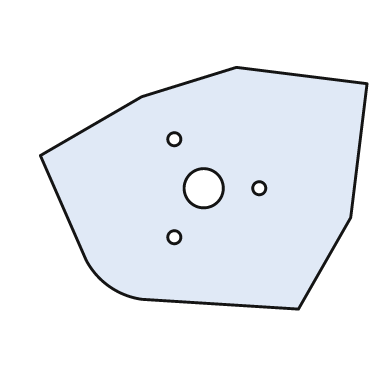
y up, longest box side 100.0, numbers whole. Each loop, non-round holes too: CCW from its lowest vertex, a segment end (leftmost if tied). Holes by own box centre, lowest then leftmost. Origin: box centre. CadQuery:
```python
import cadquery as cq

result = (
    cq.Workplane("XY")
    .moveTo(29.0, -37.0)
    .lineTo(45.0, -9.0)
    .lineTo(50.0, 32.0)
    .lineTo(10.0, 37.0)
    .lineTo(-19.0, 28.0)
    .lineTo(-50.0, 10.0)
    .lineTo(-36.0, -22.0)
    .threePointArc((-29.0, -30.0), (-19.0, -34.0))
    .close()
    .moveTo(-9.0, -15.0)
    .circle(2.0)
    .moveTo(0.0, 0.0)
    .circle(6.0)
    .moveTo(17.0, 0.0)
    .circle(2.0)
    .moveTo(-9.0, 15.0)
    .circle(2.0)
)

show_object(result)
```